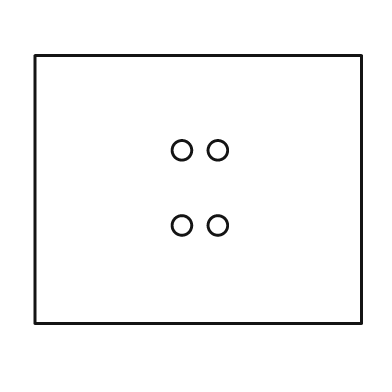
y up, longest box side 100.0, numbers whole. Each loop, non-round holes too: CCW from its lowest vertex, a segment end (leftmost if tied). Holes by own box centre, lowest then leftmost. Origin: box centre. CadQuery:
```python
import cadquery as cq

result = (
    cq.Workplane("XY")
    .moveTo(-50.0, -41.0)
    .lineTo(50.0, -41.0)
    .lineTo(50.0, 41.0)
    .lineTo(-50.0, 41.0)
    .close()
    .moveTo(-5.0, -11.0)
    .circle(3.0)
    .moveTo(6.0, -11.0)
    .circle(3.0)
    .moveTo(-5.0, 12.0)
    .circle(3.0)
    .moveTo(6.0, 12.0)
    .circle(3.0)
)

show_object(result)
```